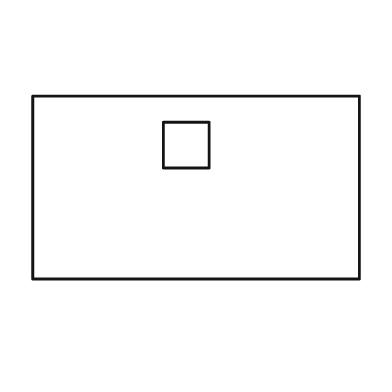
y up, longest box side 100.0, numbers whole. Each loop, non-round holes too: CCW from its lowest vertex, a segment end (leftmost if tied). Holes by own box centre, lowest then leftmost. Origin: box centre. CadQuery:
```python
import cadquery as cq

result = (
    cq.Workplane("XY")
    .moveTo(-50.0, -28.0)
    .lineTo(50.0, -28.0)
    .lineTo(50.0, 28.0)
    .lineTo(-50.0, 28.0)
    .close()
    .moveTo(-10.0, 6.0)
    .lineTo(4.0, 6.0)
    .lineTo(4.0, 20.0)
    .lineTo(-10.0, 20.0)
    .close()
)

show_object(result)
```